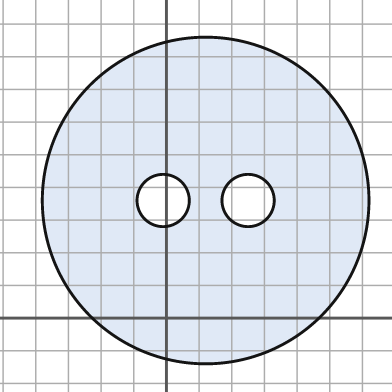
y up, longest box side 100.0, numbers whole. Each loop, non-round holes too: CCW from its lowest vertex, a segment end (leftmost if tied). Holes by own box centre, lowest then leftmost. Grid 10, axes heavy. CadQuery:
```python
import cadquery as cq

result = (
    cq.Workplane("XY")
    .moveTo(12.0, 36.0)
    .circle(50.0)
    .moveTo(-1.0, 36.0)
    .circle(8.0)
    .moveTo(25.0, 36.0)
    .circle(8.0)
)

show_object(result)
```